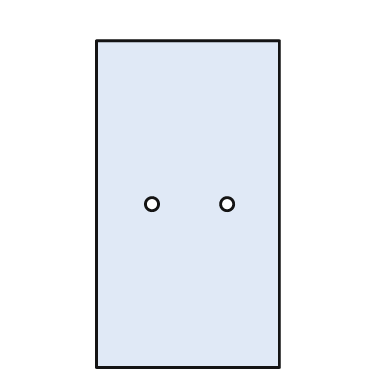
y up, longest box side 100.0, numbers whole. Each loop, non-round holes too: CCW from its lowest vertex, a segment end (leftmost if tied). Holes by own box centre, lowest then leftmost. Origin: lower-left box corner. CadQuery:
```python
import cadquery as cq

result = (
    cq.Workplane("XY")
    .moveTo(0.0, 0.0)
    .lineTo(56.0, 0.0)
    .lineTo(56.0, 100.0)
    .lineTo(0.0, 100.0)
    .close()
    .moveTo(17.0, 50.0)
    .circle(2.0)
    .moveTo(40.0, 50.0)
    .circle(2.0)
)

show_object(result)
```